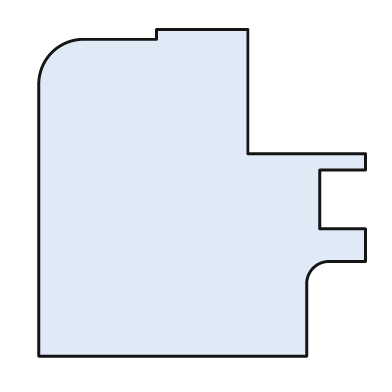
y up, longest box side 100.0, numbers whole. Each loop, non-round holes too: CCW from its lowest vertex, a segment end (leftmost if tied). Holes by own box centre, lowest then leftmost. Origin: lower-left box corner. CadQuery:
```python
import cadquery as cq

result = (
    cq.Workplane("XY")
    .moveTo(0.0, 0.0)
    .lineTo(82.0, 0.0)
    .lineTo(82.0, 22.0)
    .threePointArc((84.0, 27.0), (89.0, 29.0))
    .lineTo(100.0, 29.0)
    .lineTo(100.0, 39.0)
    .lineTo(86.0, 39.0)
    .lineTo(86.0, 57.0)
    .lineTo(100.0, 57.0)
    .lineTo(100.0, 62.0)
    .lineTo(64.0, 62.0)
    .lineTo(64.0, 100.0)
    .lineTo(36.0, 100.0)
    .lineTo(36.0, 97.0)
    .lineTo(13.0, 97.0)
    .threePointArc((4.0, 93.0), (0.0, 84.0))
    .close()
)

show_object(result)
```